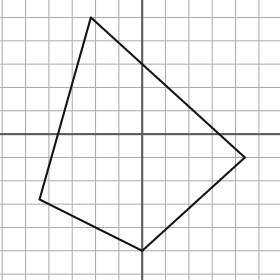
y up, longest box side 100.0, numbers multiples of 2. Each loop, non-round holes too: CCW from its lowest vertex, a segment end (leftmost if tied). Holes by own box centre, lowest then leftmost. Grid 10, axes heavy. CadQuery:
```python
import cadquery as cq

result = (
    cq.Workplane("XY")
    .moveTo(0.0, -50.0)
    .lineTo(44.0, -10.0)
    .lineTo(-22.0, 50.0)
    .lineTo(-44.0, -28.0)
    .close()
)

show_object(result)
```